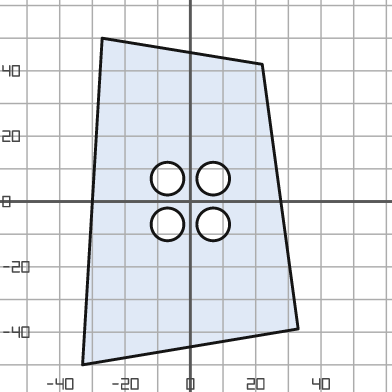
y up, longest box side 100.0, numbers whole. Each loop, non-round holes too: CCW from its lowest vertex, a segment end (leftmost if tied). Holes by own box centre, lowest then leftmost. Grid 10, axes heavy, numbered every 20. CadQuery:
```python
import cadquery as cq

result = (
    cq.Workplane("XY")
    .moveTo(-33.0, -50.0)
    .lineTo(33.0, -39.0)
    .lineTo(22.0, 42.0)
    .lineTo(-27.0, 50.0)
    .close()
    .moveTo(-7.0, -7.0)
    .circle(5.0)
    .moveTo(7.0, -7.0)
    .circle(5.0)
    .moveTo(-7.0, 7.0)
    .circle(5.0)
    .moveTo(7.0, 7.0)
    .circle(5.0)
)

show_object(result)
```